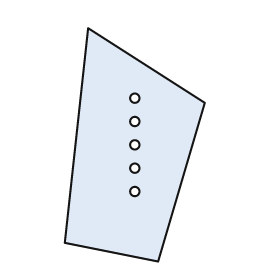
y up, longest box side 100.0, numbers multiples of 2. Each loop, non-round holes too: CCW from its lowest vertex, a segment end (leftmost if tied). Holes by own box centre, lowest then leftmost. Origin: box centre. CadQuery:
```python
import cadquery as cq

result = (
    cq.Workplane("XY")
    .moveTo(10.0, -50.0)
    .lineTo(30.0, 18.0)
    .lineTo(-20.0, 50.0)
    .lineTo(-30.0, -42.0)
    .close()
    .moveTo(0.0, -20.0)
    .circle(2.0)
    .moveTo(0.0, -10.0)
    .circle(2.0)
    .moveTo(0.0, 0.0)
    .circle(2.0)
    .moveTo(0.0, 10.0)
    .circle(2.0)
    .moveTo(0.0, 20.0)
    .circle(2.0)
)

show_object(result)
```